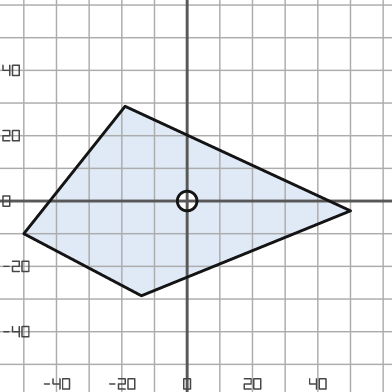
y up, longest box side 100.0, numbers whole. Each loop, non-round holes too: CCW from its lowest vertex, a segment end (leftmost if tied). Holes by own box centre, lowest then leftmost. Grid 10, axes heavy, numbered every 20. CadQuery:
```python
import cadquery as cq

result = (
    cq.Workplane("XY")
    .moveTo(-14.0, -29.0)
    .lineTo(50.0, -3.0)
    .lineTo(-19.0, 29.0)
    .lineTo(-50.0, -10.0)
    .close()
    .moveTo(0.0, 0.0)
    .circle(3.0)
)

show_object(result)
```